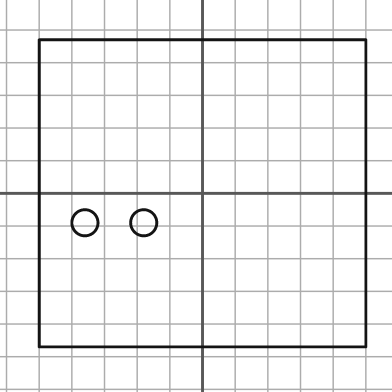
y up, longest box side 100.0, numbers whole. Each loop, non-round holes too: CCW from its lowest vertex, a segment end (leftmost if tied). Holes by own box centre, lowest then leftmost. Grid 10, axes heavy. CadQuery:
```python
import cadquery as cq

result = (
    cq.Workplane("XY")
    .moveTo(-50.0, -47.0)
    .lineTo(50.0, -47.0)
    .lineTo(50.0, 47.0)
    .lineTo(-50.0, 47.0)
    .close()
    .moveTo(-36.0, -9.0)
    .circle(4.0)
    .moveTo(-18.0, -9.0)
    .circle(4.0)
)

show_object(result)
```